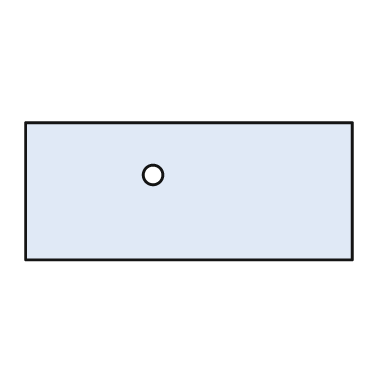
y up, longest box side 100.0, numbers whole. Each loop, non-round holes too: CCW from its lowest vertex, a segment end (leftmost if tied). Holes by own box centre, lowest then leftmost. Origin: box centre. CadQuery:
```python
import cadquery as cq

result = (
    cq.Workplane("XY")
    .moveTo(-50.0, -21.0)
    .lineTo(50.0, -21.0)
    .lineTo(50.0, 21.0)
    .lineTo(-50.0, 21.0)
    .close()
    .moveTo(-11.0, 5.0)
    .circle(3.0)
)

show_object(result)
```